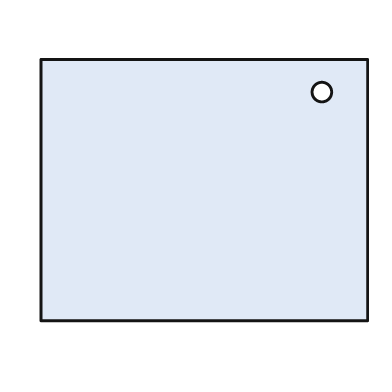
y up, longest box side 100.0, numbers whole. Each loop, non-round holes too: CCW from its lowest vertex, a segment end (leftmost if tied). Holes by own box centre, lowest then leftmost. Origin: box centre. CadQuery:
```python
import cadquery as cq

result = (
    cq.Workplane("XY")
    .moveTo(-50.0, -40.0)
    .lineTo(50.0, -40.0)
    .lineTo(50.0, 40.0)
    .lineTo(-50.0, 40.0)
    .close()
    .moveTo(36.0, 30.0)
    .circle(3.0)
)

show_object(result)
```